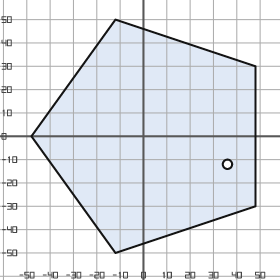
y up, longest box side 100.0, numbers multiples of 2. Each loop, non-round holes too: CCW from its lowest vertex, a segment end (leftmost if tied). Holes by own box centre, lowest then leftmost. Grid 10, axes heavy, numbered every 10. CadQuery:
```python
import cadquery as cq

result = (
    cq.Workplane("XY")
    .moveTo(-12.0, -50.0)
    .lineTo(48.0, -30.0)
    .lineTo(48.0, 30.0)
    .lineTo(-12.0, 50.0)
    .lineTo(-48.0, 0.0)
    .close()
    .moveTo(36.0, -12.0)
    .circle(2.0)
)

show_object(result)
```